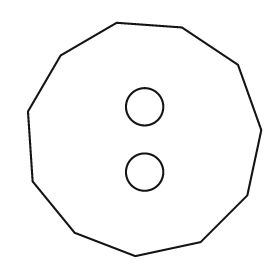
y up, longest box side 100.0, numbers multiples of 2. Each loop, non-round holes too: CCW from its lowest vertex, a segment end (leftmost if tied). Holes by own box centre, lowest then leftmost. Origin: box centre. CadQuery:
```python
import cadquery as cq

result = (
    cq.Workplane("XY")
    .moveTo(-4.0, -50.0)
    .lineTo(24.0, -44.0)
    .lineTo(44.0, -24.0)
    .lineTo(50.0, 4.0)
    .lineTo(40.0, 32.0)
    .lineTo(16.0, 48.0)
    .lineTo(-12.0, 50.0)
    .lineTo(-36.0, 36.0)
    .lineTo(-50.0, 12.0)
    .lineTo(-48.0, -18.0)
    .lineTo(-30.0, -40.0)
    .close()
    .moveTo(0.0, -14.0)
    .circle(8.0)
    .moveTo(0.0, 14.0)
    .circle(8.0)
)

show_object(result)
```